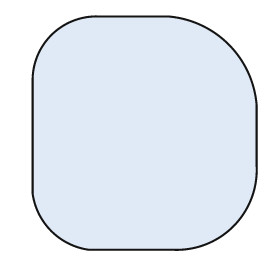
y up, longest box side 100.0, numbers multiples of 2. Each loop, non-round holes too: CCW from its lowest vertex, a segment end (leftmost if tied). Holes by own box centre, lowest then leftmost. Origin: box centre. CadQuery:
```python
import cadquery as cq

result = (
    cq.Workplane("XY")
    .moveTo(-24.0, -50.0)
    .lineTo(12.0, -50.0)
    .threePointArc((38.0, -40.0), (48.0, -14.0))
    .lineTo(48.0, 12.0)
    .threePointArc((36.0, 38.0), (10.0, 50.0))
    .lineTo(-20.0, 50.0)
    .threePointArc((-40.0, 42.0), (-48.0, 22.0))
    .lineTo(-48.0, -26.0)
    .threePointArc((-40.0, -42.0), (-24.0, -50.0))
    .close()
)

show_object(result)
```